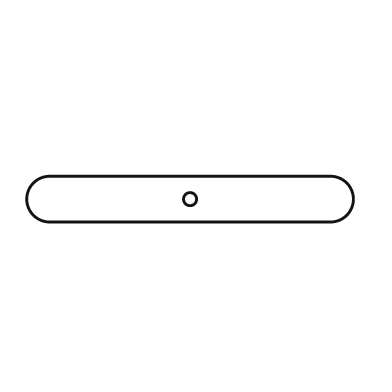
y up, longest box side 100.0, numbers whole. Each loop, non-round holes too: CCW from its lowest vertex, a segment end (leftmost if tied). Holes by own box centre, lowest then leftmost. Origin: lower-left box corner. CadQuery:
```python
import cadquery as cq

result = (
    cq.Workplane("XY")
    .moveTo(7.0, 0.0)
    .lineTo(93.0, 0.0)
    .threePointArc((100.0, 7.0), (93.0, 14.0))
    .lineTo(7.0, 14.0)
    .threePointArc((0.0, 7.0), (7.0, 0.0))
    .close()
    .moveTo(50.0, 7.0)
    .circle(2.0)
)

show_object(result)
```